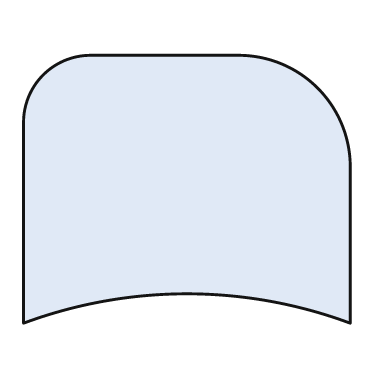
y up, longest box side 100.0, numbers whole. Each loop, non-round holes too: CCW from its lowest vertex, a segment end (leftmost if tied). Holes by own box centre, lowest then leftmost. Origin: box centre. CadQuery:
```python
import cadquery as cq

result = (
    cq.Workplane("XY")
    .moveTo(-50.0, -41.0)
    .threePointArc((0.0, -32.0), (50.0, -41.0))
    .lineTo(50.0, 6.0)
    .threePointArc((40.0, 31.0), (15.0, 41.0))
    .lineTo(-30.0, 41.0)
    .threePointArc((-44.0, 35.0), (-50.0, 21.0))
    .close()
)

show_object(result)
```